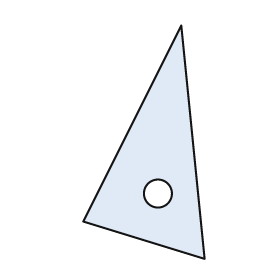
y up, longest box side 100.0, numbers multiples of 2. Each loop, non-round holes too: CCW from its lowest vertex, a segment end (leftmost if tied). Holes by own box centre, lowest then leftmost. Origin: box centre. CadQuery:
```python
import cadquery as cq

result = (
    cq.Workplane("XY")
    .moveTo(26.0, -50.0)
    .lineTo(16.0, 50.0)
    .lineTo(-26.0, -34.0)
    .close()
    .moveTo(6.0, -22.0)
    .circle(6.0)
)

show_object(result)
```